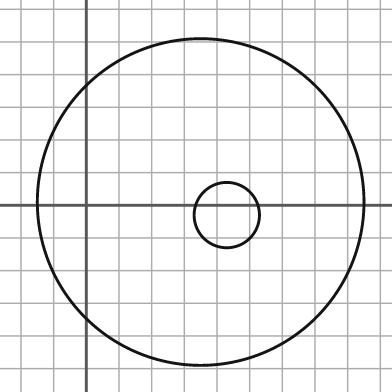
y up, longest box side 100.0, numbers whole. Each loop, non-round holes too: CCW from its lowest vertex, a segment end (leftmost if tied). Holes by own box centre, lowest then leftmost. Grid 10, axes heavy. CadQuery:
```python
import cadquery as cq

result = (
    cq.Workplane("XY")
    .moveTo(35.0, 1.0)
    .circle(50.0)
    .moveTo(43.0, -3.0)
    .circle(10.0)
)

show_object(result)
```